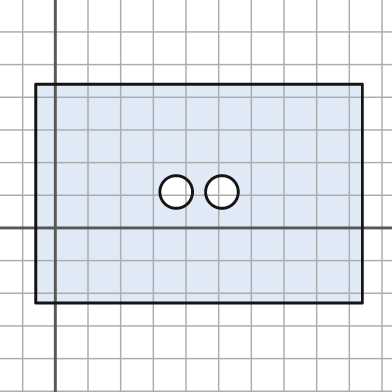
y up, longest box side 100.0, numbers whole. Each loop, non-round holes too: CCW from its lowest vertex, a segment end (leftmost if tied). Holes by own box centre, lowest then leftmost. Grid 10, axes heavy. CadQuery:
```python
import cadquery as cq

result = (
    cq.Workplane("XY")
    .moveTo(-6.0, -23.0)
    .lineTo(94.0, -23.0)
    .lineTo(94.0, 44.0)
    .lineTo(-6.0, 44.0)
    .close()
    .moveTo(37.0, 11.0)
    .circle(5.0)
    .moveTo(51.0, 11.0)
    .circle(5.0)
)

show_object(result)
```